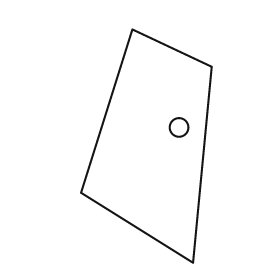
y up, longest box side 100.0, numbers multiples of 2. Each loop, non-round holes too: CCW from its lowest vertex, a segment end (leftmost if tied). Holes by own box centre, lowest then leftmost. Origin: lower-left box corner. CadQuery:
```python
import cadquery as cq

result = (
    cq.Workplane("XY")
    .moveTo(48.0, 0.0)
    .lineTo(56.0, 84.0)
    .lineTo(22.0, 100.0)
    .lineTo(0.0, 30.0)
    .close()
    .moveTo(42.0, 58.0)
    .circle(4.0)
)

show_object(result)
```